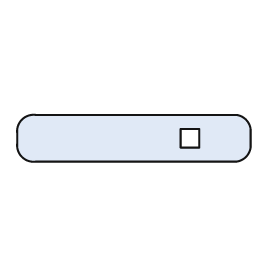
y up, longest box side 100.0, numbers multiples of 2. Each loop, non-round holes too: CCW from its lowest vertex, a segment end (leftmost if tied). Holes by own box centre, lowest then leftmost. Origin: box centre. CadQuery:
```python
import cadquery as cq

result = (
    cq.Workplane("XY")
    .moveTo(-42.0, -10.0)
    .lineTo(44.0, -10.0)
    .threePointArc((48.0, -8.0), (50.0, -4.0))
    .lineTo(50.0, 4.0)
    .threePointArc((48.0, 8.0), (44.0, 10.0))
    .lineTo(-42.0, 10.0)
    .threePointArc((-48.0, 8.0), (-50.0, 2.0))
    .lineTo(-50.0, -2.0)
    .threePointArc((-48.0, -8.0), (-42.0, -10.0))
    .close()
    .moveTo(20.0, -4.0)
    .lineTo(28.0, -4.0)
    .lineTo(28.0, 4.0)
    .lineTo(20.0, 4.0)
    .close()
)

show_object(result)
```